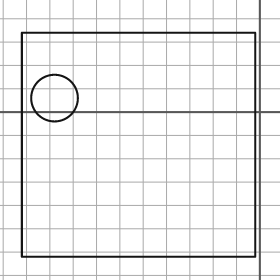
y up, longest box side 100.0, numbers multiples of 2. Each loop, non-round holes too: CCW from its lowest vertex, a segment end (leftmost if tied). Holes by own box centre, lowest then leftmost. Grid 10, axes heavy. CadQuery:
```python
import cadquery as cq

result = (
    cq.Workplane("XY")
    .moveTo(-102.0, -62.0)
    .lineTo(-2.0, -62.0)
    .lineTo(-2.0, 34.0)
    .lineTo(-102.0, 34.0)
    .close()
    .moveTo(-88.0, 6.0)
    .circle(10.0)
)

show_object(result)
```